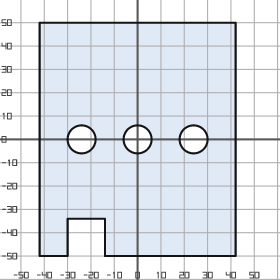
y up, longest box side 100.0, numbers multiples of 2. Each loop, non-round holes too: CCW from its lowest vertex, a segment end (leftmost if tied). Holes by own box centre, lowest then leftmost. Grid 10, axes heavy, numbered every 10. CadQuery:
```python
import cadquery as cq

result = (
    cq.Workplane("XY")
    .moveTo(-42.0, -50.0)
    .lineTo(-30.0, -50.0)
    .lineTo(-30.0, -34.0)
    .lineTo(-14.0, -34.0)
    .lineTo(-14.0, -50.0)
    .lineTo(42.0, -50.0)
    .lineTo(42.0, 50.0)
    .lineTo(-42.0, 50.0)
    .close()
    .moveTo(-24.0, 0.0)
    .circle(6.0)
    .moveTo(0.0, 0.0)
    .circle(6.0)
    .moveTo(24.0, 0.0)
    .circle(6.0)
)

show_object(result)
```